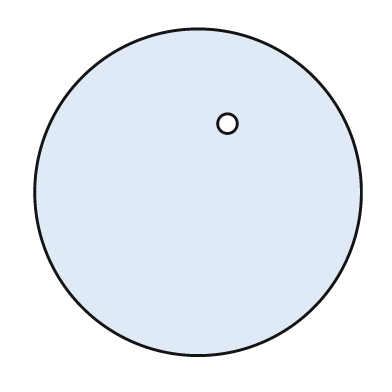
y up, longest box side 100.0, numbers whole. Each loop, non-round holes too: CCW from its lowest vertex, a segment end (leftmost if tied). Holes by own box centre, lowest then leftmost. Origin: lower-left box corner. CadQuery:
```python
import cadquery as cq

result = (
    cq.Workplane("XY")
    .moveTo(50.0, 50.0)
    .circle(50.0)
    .moveTo(59.0, 71.0)
    .circle(3.0)
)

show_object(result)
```